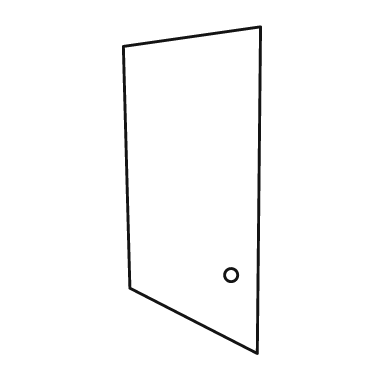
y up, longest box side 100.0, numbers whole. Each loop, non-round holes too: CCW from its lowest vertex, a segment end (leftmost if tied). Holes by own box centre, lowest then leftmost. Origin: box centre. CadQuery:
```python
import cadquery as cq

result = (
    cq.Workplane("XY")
    .moveTo(20.0, -50.0)
    .lineTo(21.0, 50.0)
    .lineTo(-21.0, 44.0)
    .lineTo(-19.0, -30.0)
    .close()
    .moveTo(12.0, -26.0)
    .circle(2.0)
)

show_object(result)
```